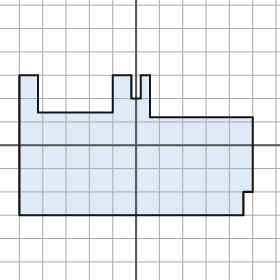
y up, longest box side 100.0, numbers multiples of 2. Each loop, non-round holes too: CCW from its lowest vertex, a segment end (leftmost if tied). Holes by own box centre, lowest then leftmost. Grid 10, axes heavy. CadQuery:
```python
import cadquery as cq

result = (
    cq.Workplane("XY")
    .moveTo(-50.0, -30.0)
    .lineTo(46.0, -30.0)
    .lineTo(46.0, -20.0)
    .lineTo(50.0, -20.0)
    .lineTo(50.0, 12.0)
    .lineTo(6.0, 12.0)
    .lineTo(6.0, 30.0)
    .lineTo(2.0, 30.0)
    .lineTo(2.0, 20.0)
    .lineTo(-2.0, 20.0)
    .lineTo(-2.0, 30.0)
    .lineTo(-10.0, 30.0)
    .lineTo(-10.0, 14.0)
    .lineTo(-42.0, 14.0)
    .lineTo(-42.0, 30.0)
    .lineTo(-50.0, 30.0)
    .close()
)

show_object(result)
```